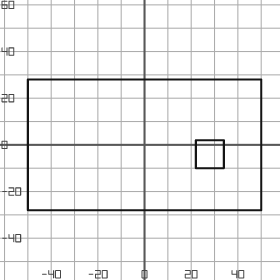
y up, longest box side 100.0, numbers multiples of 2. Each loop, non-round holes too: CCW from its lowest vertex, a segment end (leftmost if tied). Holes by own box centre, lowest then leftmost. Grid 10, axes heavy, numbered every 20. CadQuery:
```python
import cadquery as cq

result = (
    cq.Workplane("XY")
    .moveTo(-50.0, -28.0)
    .lineTo(50.0, -28.0)
    .lineTo(50.0, 28.0)
    .lineTo(-50.0, 28.0)
    .close()
    .moveTo(22.0, -10.0)
    .lineTo(34.0, -10.0)
    .lineTo(34.0, 2.0)
    .lineTo(22.0, 2.0)
    .close()
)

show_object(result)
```